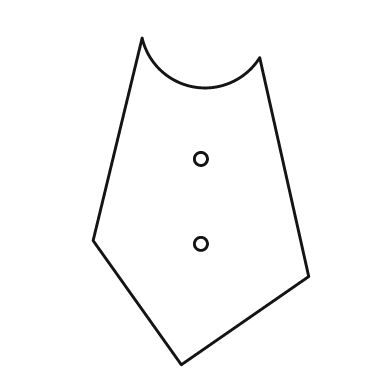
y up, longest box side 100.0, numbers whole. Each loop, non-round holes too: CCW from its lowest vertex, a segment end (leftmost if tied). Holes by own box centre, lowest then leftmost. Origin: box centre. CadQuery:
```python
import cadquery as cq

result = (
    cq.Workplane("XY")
    .moveTo(-6.0, -50.0)
    .lineTo(33.0, -23.0)
    .lineTo(18.0, 44.0)
    .threePointArc((-2.0, 35.0), (-18.0, 50.0))
    .lineTo(-33.0, -12.0)
    .close()
    .moveTo(0.0, -13.0)
    .circle(2.0)
    .moveTo(0.0, 13.0)
    .circle(2.0)
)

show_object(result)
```